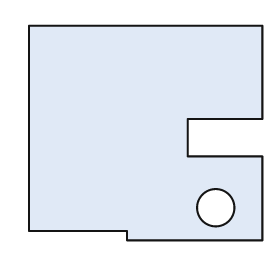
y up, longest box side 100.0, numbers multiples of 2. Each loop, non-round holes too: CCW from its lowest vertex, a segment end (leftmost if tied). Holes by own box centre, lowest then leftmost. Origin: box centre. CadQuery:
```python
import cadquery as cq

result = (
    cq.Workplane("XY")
    .moveTo(-8.0, -46.0)
    .lineTo(50.0, -46.0)
    .lineTo(50.0, -10.0)
    .lineTo(18.0, -10.0)
    .lineTo(18.0, 6.0)
    .lineTo(50.0, 6.0)
    .lineTo(50.0, 46.0)
    .lineTo(-50.0, 46.0)
    .lineTo(-50.0, -42.0)
    .lineTo(-8.0, -42.0)
    .close()
    .moveTo(30.0, -32.0)
    .circle(8.0)
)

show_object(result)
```